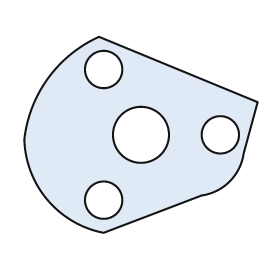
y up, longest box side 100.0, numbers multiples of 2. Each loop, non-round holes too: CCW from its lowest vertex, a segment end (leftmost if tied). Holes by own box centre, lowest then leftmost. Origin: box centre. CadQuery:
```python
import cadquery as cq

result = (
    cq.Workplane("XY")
    .moveTo(-16.0, -42.0)
    .lineTo(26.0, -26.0)
    .threePointArc((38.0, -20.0), (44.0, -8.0))
    .lineTo(50.0, 14.0)
    .lineTo(-18.0, 42.0)
    .threePointArc((-40.0, 24.0), (-50.0, -2.0))
    .threePointArc((-40.0, -28.0), (-16.0, -42.0))
    .close()
    .moveTo(-16.0, -28.0)
    .circle(8.0)
    .moveTo(0.0, 0.0)
    .circle(12.0)
    .moveTo(34.0, 0.0)
    .circle(8.0)
    .moveTo(-16.0, 28.0)
    .circle(8.0)
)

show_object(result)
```